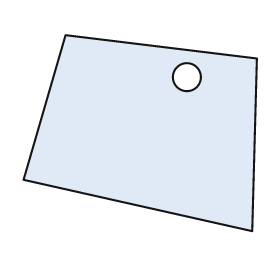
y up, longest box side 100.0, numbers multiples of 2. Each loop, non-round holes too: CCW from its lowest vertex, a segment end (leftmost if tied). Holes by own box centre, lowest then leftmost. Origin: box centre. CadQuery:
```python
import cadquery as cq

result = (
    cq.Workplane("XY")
    .moveTo(48.0, -42.0)
    .lineTo(50.0, 32.0)
    .lineTo(-32.0, 42.0)
    .lineTo(-50.0, -20.0)
    .close()
    .moveTo(20.0, 24.0)
    .circle(6.0)
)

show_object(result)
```